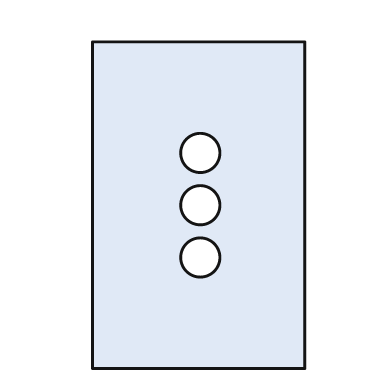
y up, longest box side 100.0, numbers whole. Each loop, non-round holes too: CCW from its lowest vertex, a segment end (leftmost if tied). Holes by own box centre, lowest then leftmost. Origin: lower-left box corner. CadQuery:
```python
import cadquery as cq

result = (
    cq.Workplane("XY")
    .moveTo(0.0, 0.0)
    .lineTo(65.0, 0.0)
    .lineTo(65.0, 100.0)
    .lineTo(0.0, 100.0)
    .close()
    .moveTo(33.0, 34.0)
    .circle(6.0)
    .moveTo(33.0, 50.0)
    .circle(6.0)
    .moveTo(33.0, 66.0)
    .circle(6.0)
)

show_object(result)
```